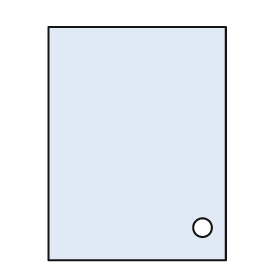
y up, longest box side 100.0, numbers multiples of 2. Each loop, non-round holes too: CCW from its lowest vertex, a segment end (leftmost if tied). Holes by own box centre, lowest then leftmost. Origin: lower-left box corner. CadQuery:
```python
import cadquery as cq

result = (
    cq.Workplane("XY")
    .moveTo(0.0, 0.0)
    .lineTo(76.0, 0.0)
    .lineTo(76.0, 100.0)
    .lineTo(0.0, 100.0)
    .close()
    .moveTo(66.0, 14.0)
    .circle(4.0)
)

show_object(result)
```